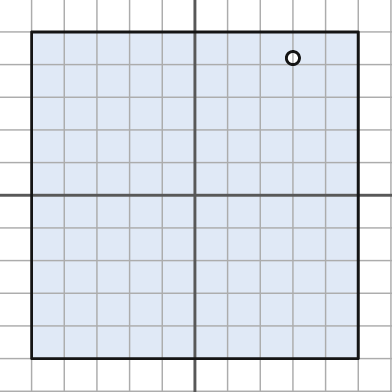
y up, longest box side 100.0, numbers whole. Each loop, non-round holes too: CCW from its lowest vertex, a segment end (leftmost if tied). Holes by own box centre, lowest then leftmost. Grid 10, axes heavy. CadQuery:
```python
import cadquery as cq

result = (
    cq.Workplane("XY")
    .moveTo(-50.0, -50.0)
    .lineTo(50.0, -50.0)
    .lineTo(50.0, 50.0)
    .lineTo(-50.0, 50.0)
    .close()
    .moveTo(30.0, 42.0)
    .circle(2.0)
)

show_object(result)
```